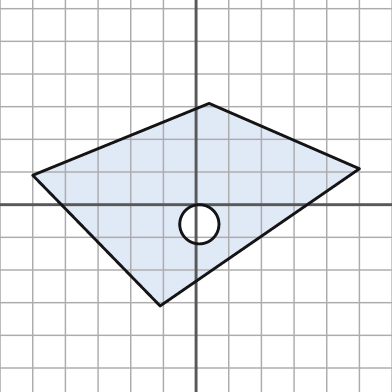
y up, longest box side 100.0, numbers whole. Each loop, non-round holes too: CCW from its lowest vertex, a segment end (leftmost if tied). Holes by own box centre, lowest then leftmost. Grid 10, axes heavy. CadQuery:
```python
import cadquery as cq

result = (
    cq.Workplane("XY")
    .moveTo(-11.0, -31.0)
    .lineTo(50.0, 11.0)
    .lineTo(4.0, 31.0)
    .lineTo(-50.0, 9.0)
    .close()
    .moveTo(1.0, -6.0)
    .circle(6.0)
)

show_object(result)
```